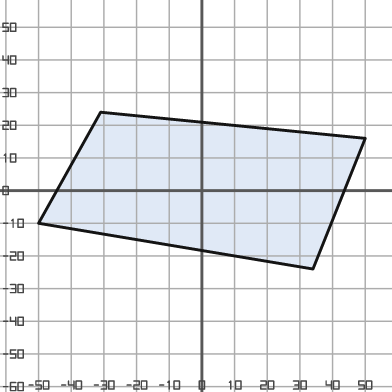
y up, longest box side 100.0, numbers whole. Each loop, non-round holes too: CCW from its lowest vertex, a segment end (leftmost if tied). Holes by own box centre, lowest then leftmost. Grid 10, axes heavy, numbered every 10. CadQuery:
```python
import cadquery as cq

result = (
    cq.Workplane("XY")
    .moveTo(34.0, -24.0)
    .lineTo(50.0, 16.0)
    .lineTo(-31.0, 24.0)
    .lineTo(-50.0, -10.0)
    .close()
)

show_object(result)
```